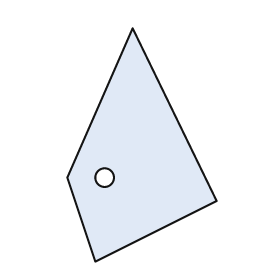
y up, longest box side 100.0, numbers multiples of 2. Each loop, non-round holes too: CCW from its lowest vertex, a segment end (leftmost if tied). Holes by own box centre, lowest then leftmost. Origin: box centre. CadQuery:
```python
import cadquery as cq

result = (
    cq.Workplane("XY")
    .moveTo(-20.0, -50.0)
    .lineTo(32.0, -24.0)
    .lineTo(-4.0, 50.0)
    .lineTo(-32.0, -14.0)
    .close()
    .moveTo(-16.0, -14.0)
    .circle(4.0)
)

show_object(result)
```